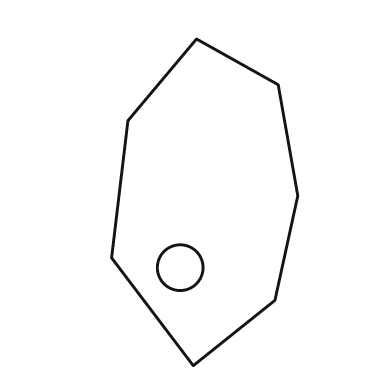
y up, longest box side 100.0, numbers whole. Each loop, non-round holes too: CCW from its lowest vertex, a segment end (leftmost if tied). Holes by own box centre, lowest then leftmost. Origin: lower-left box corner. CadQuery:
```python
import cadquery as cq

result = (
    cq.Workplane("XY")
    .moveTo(25.0, 0.0)
    .lineTo(50.0, 20.0)
    .lineTo(57.0, 52.0)
    .lineTo(51.0, 86.0)
    .lineTo(26.0, 100.0)
    .lineTo(5.0, 75.0)
    .lineTo(0.0, 33.0)
    .close()
    .moveTo(21.0, 30.0)
    .circle(7.0)
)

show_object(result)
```